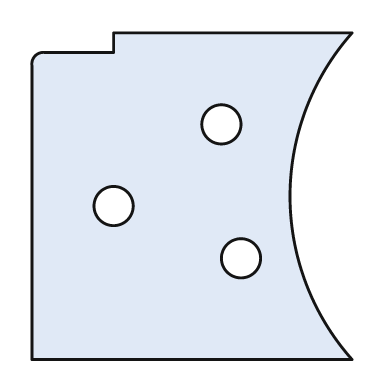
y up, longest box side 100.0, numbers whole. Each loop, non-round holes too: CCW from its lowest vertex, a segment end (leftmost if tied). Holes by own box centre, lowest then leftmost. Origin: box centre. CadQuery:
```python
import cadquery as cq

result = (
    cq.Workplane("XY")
    .moveTo(-49.0, -50.0)
    .lineTo(49.0, -50.0)
    .threePointArc((30.0, 0.0), (49.0, 50.0))
    .lineTo(-24.0, 50.0)
    .lineTo(-24.0, 44.0)
    .lineTo(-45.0, 44.0)
    .threePointArc((-48.0, 43.0), (-49.0, 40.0))
    .close()
    .moveTo(15.0, -19.0)
    .circle(6.0)
    .moveTo(-24.0, -3.0)
    .circle(6.0)
    .moveTo(9.0, 22.0)
    .circle(6.0)
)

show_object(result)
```